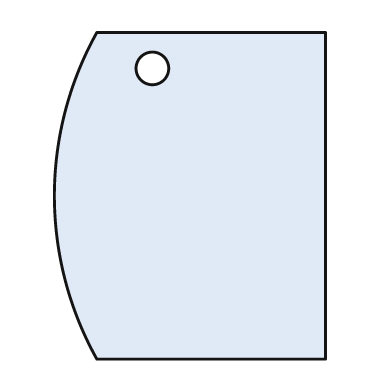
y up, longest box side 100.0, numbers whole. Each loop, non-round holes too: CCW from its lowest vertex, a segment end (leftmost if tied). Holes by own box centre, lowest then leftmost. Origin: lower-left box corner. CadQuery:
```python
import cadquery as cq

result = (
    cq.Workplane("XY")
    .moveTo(13.0, 0.0)
    .lineTo(83.0, 0.0)
    .lineTo(83.0, 100.0)
    .lineTo(13.0, 100.0)
    .threePointArc((0.0, 50.0), (13.0, 0.0))
    .close()
    .moveTo(30.0, 89.0)
    .circle(5.0)
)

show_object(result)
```